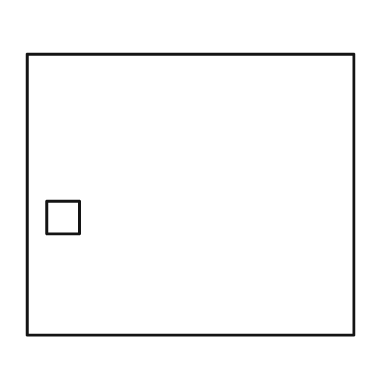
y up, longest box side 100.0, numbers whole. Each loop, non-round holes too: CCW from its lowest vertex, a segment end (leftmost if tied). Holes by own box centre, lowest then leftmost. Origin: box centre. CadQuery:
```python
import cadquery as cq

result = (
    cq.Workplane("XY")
    .moveTo(-50.0, -43.0)
    .lineTo(50.0, -43.0)
    .lineTo(50.0, 43.0)
    .lineTo(-50.0, 43.0)
    .close()
    .moveTo(-44.0, -12.0)
    .lineTo(-34.0, -12.0)
    .lineTo(-34.0, -2.0)
    .lineTo(-44.0, -2.0)
    .close()
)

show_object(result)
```